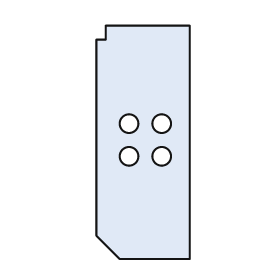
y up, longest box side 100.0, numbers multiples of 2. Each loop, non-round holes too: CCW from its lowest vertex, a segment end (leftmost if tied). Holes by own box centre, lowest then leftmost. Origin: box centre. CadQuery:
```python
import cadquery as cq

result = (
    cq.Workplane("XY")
    .moveTo(-10.0, -50.0)
    .lineTo(20.0, -50.0)
    .lineTo(20.0, 50.0)
    .lineTo(-16.0, 50.0)
    .lineTo(-16.0, 44.0)
    .lineTo(-20.0, 44.0)
    .lineTo(-20.0, -40.0)
    .close()
    .moveTo(-6.0, -6.0)
    .circle(4.0)
    .moveTo(8.0, -6.0)
    .circle(4.0)
    .moveTo(-6.0, 8.0)
    .circle(4.0)
    .moveTo(8.0, 8.0)
    .circle(4.0)
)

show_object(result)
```